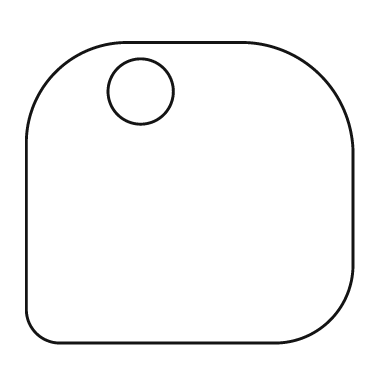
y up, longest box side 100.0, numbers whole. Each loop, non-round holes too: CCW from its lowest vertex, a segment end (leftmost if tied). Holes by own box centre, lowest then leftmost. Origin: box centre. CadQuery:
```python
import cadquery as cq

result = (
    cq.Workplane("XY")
    .moveTo(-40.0, -46.0)
    .lineTo(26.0, -46.0)
    .threePointArc((43.0, -39.0), (50.0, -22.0))
    .lineTo(50.0, 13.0)
    .threePointArc((40.0, 36.0), (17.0, 46.0))
    .lineTo(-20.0, 46.0)
    .threePointArc((-41.0, 37.0), (-50.0, 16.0))
    .lineTo(-50.0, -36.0)
    .threePointArc((-47.0, -43.0), (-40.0, -46.0))
    .close()
    .moveTo(-15.0, 31.0)
    .circle(10.0)
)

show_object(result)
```